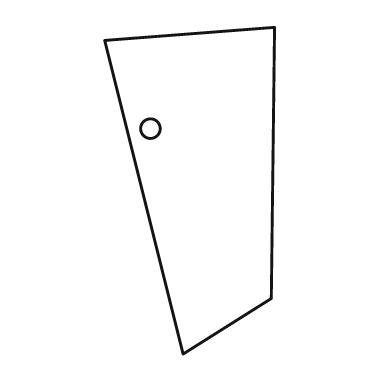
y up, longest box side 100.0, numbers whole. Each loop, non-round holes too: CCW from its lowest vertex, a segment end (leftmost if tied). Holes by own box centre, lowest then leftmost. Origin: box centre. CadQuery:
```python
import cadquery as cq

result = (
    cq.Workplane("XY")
    .moveTo(-2.0, -50.0)
    .lineTo(25.0, -33.0)
    .lineTo(26.0, 50.0)
    .lineTo(-26.0, 46.0)
    .close()
    .moveTo(-12.0, 19.0)
    .circle(3.0)
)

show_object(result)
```